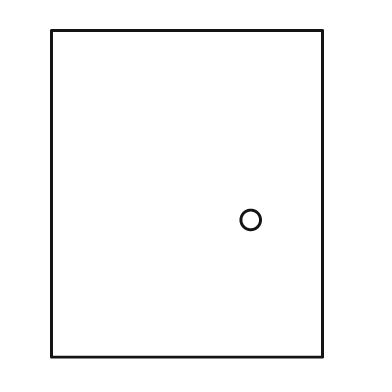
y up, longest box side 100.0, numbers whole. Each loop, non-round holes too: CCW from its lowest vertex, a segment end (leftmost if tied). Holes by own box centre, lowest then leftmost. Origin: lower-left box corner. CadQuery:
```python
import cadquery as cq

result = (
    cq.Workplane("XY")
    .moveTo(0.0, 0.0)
    .lineTo(83.0, 0.0)
    .lineTo(83.0, 100.0)
    .lineTo(0.0, 100.0)
    .close()
    .moveTo(61.0, 42.0)
    .circle(3.0)
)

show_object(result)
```